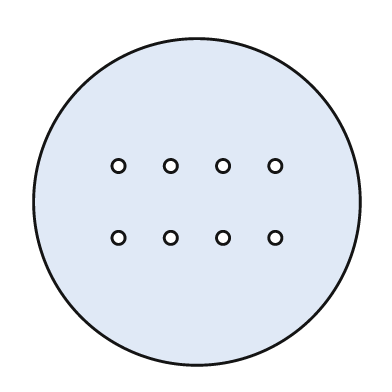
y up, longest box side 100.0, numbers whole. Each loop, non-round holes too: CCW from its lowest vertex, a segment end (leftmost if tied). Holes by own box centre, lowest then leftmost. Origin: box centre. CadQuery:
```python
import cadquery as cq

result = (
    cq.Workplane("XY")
    .moveTo(0.0, 0.0)
    .circle(50.0)
    .moveTo(-24.0, -11.0)
    .circle(2.0)
    .moveTo(-8.0, -11.0)
    .circle(2.0)
    .moveTo(8.0, -11.0)
    .circle(2.0)
    .moveTo(24.0, -11.0)
    .circle(2.0)
    .moveTo(-24.0, 11.0)
    .circle(2.0)
    .moveTo(-8.0, 11.0)
    .circle(2.0)
    .moveTo(8.0, 11.0)
    .circle(2.0)
    .moveTo(24.0, 11.0)
    .circle(2.0)
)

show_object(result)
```